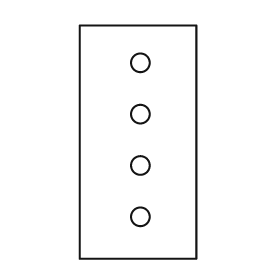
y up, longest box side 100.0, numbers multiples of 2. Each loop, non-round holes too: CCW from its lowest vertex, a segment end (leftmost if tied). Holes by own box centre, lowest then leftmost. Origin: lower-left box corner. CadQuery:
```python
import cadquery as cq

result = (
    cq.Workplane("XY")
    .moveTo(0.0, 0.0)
    .lineTo(50.0, 0.0)
    .lineTo(50.0, 100.0)
    .lineTo(0.0, 100.0)
    .close()
    .moveTo(26.0, 18.0)
    .circle(4.0)
    .moveTo(26.0, 40.0)
    .circle(4.0)
    .moveTo(26.0, 62.0)
    .circle(4.0)
    .moveTo(26.0, 84.0)
    .circle(4.0)
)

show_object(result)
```